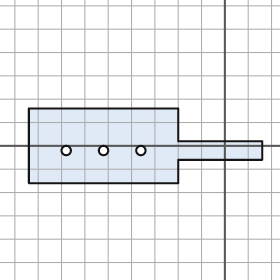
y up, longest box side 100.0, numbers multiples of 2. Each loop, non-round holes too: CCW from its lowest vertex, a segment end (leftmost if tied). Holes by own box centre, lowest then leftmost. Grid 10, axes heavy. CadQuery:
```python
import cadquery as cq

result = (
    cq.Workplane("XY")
    .moveTo(-84.0, -16.0)
    .lineTo(-20.0, -16.0)
    .lineTo(-20.0, -6.0)
    .lineTo(16.0, -6.0)
    .lineTo(16.0, 2.0)
    .lineTo(-20.0, 2.0)
    .lineTo(-20.0, 16.0)
    .lineTo(-84.0, 16.0)
    .close()
    .moveTo(-68.0, -2.0)
    .circle(2.0)
    .moveTo(-52.0, -2.0)
    .circle(2.0)
    .moveTo(-36.0, -2.0)
    .circle(2.0)
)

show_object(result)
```